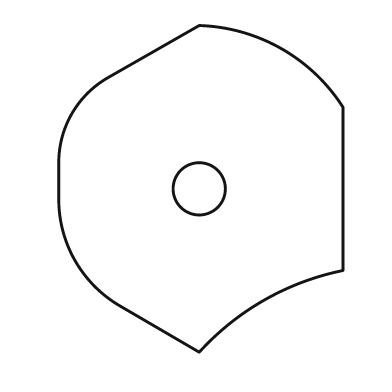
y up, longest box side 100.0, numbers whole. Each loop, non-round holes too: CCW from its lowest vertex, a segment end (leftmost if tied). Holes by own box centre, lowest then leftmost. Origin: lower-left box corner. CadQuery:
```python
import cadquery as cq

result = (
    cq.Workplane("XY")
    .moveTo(43.0, 0.0)
    .threePointArc((63.0, 16.0), (87.0, 25.0))
    .lineTo(87.0, 75.0)
    .threePointArc((68.0, 93.0), (43.0, 100.0))
    .lineTo(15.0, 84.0)
    .threePointArc((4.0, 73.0), (0.0, 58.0))
    .lineTo(0.0, 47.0)
    .threePointArc((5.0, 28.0), (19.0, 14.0))
    .close()
    .moveTo(43.0, 50.0)
    .circle(8.0)
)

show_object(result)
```